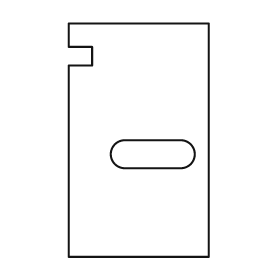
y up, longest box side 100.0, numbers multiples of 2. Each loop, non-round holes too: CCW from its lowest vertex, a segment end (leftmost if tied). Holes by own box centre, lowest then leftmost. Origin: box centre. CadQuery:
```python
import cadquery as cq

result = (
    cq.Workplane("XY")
    .moveTo(-30.0, -50.0)
    .lineTo(30.0, -50.0)
    .lineTo(30.0, 50.0)
    .lineTo(-30.0, 50.0)
    .lineTo(-30.0, 40.0)
    .lineTo(-20.0, 40.0)
    .lineTo(-20.0, 32.0)
    .lineTo(-30.0, 32.0)
    .close()
    .moveTo(-6.0, -12.0)
    .lineTo(18.0, -12.0)
    .threePointArc((24.0, -6.0), (18.0, 0.0))
    .lineTo(-6.0, 0.0)
    .threePointArc((-12.0, -6.0), (-6.0, -12.0))
    .close()
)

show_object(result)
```